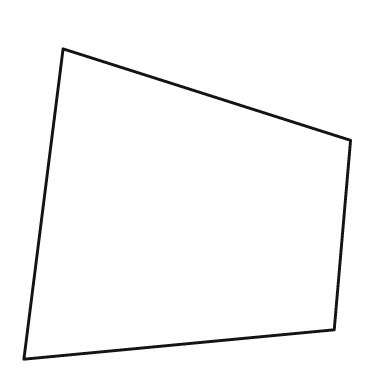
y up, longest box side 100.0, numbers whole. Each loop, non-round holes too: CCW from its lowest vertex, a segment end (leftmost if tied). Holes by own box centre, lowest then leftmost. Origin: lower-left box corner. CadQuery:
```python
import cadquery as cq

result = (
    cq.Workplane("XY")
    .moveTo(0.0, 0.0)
    .lineTo(95.0, 9.0)
    .lineTo(100.0, 67.0)
    .lineTo(12.0, 95.0)
    .close()
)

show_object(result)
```